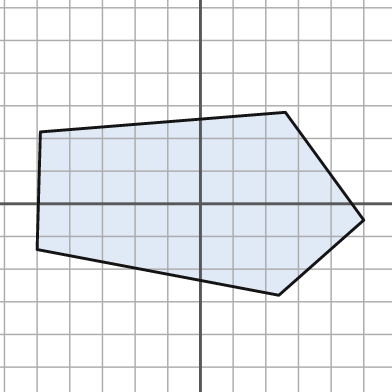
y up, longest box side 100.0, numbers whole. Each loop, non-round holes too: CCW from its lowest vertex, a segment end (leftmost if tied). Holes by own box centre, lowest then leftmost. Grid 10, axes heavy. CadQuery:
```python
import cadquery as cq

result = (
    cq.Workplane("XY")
    .moveTo(24.0, -28.0)
    .lineTo(50.0, -5.0)
    .lineTo(26.0, 28.0)
    .lineTo(-49.0, 22.0)
    .lineTo(-50.0, -14.0)
    .close()
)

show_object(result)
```